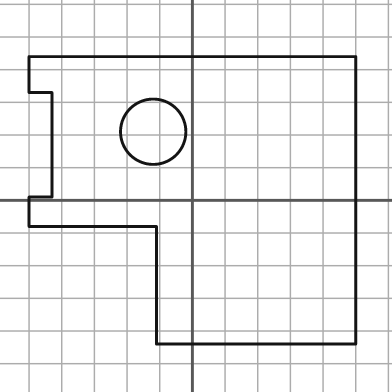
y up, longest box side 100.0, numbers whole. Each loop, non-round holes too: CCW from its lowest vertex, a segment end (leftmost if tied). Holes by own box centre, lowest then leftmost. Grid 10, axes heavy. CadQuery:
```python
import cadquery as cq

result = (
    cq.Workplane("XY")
    .moveTo(-11.0, -44.0)
    .lineTo(50.0, -44.0)
    .lineTo(50.0, 44.0)
    .lineTo(-50.0, 44.0)
    .lineTo(-50.0, 33.0)
    .lineTo(-43.0, 33.0)
    .lineTo(-43.0, 1.0)
    .lineTo(-50.0, 1.0)
    .lineTo(-50.0, -8.0)
    .lineTo(-11.0, -8.0)
    .close()
    .moveTo(-12.0, 21.0)
    .circle(10.0)
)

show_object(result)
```